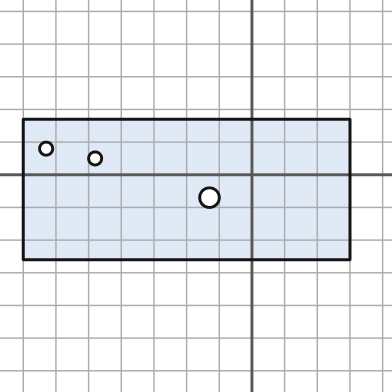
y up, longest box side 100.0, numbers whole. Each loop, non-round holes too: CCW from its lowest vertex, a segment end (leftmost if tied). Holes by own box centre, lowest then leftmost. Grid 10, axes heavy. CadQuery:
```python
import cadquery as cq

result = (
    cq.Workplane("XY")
    .moveTo(-70.0, -26.0)
    .lineTo(30.0, -26.0)
    .lineTo(30.0, 17.0)
    .lineTo(-70.0, 17.0)
    .close()
    .moveTo(-13.0, -7.0)
    .circle(3.0)
    .moveTo(-48.0, 5.0)
    .circle(2.0)
    .moveTo(-63.0, 8.0)
    .circle(2.0)
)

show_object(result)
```